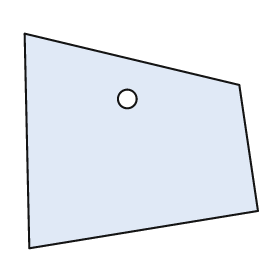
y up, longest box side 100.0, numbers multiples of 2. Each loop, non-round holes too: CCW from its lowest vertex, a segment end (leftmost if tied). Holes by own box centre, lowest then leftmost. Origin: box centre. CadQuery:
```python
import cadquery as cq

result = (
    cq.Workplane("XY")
    .moveTo(-48.0, -46.0)
    .lineTo(50.0, -30.0)
    .lineTo(42.0, 24.0)
    .lineTo(-50.0, 46.0)
    .close()
    .moveTo(-6.0, 18.0)
    .circle(4.0)
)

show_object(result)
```